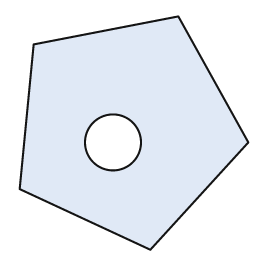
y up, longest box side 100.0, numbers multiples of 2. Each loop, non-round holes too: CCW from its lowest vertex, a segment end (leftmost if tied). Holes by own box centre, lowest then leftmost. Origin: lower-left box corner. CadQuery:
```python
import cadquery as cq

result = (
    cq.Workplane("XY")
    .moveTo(56.0, 0.0)
    .lineTo(98.0, 46.0)
    .lineTo(68.0, 100.0)
    .lineTo(6.0, 88.0)
    .lineTo(0.0, 26.0)
    .close()
    .moveTo(40.0, 46.0)
    .circle(12.0)
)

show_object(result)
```